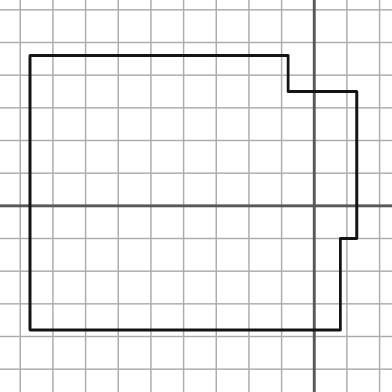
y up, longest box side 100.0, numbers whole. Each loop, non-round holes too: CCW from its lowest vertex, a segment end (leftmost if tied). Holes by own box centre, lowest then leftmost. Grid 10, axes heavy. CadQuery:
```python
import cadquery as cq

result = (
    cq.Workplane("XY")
    .moveTo(-87.0, -38.0)
    .lineTo(8.0, -38.0)
    .lineTo(8.0, -10.0)
    .lineTo(13.0, -10.0)
    .lineTo(13.0, 35.0)
    .lineTo(-8.0, 35.0)
    .lineTo(-8.0, 46.0)
    .lineTo(-87.0, 46.0)
    .close()
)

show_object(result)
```